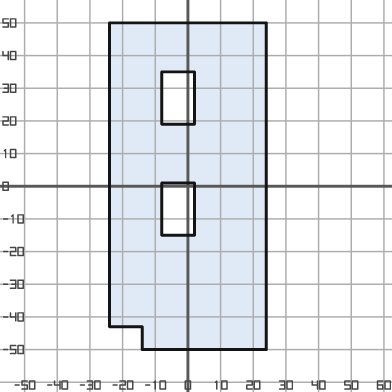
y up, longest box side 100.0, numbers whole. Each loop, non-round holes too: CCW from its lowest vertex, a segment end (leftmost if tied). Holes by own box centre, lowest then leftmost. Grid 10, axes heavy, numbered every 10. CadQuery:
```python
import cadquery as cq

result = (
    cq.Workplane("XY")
    .moveTo(-14.0, -50.0)
    .lineTo(24.0, -50.0)
    .lineTo(24.0, 50.0)
    .lineTo(-24.0, 50.0)
    .lineTo(-24.0, -43.0)
    .lineTo(-14.0, -43.0)
    .close()
    .moveTo(-8.0, -15.0)
    .lineTo(2.0, -15.0)
    .lineTo(2.0, 1.0)
    .lineTo(-8.0, 1.0)
    .close()
    .moveTo(-8.0, 19.0)
    .lineTo(2.0, 19.0)
    .lineTo(2.0, 35.0)
    .lineTo(-8.0, 35.0)
    .close()
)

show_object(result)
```